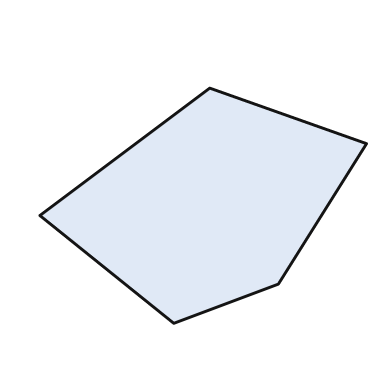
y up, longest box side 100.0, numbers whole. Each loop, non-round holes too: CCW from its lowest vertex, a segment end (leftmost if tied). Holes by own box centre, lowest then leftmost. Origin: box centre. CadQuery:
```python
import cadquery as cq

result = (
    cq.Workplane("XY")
    .moveTo(-9.0, -36.0)
    .lineTo(23.0, -24.0)
    .lineTo(50.0, 19.0)
    .lineTo(2.0, 36.0)
    .lineTo(-50.0, -3.0)
    .close()
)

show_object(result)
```